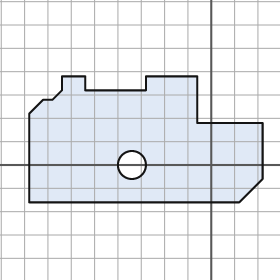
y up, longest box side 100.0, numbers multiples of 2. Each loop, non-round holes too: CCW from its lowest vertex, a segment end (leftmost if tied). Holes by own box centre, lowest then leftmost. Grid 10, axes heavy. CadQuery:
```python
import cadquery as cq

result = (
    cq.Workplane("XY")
    .moveTo(-78.0, -16.0)
    .lineTo(12.0, -16.0)
    .lineTo(22.0, -6.0)
    .lineTo(22.0, 18.0)
    .lineTo(-6.0, 18.0)
    .lineTo(-6.0, 38.0)
    .lineTo(-28.0, 38.0)
    .lineTo(-28.0, 32.0)
    .lineTo(-54.0, 32.0)
    .lineTo(-54.0, 38.0)
    .lineTo(-64.0, 38.0)
    .lineTo(-64.0, 32.0)
    .lineTo(-68.0, 28.0)
    .lineTo(-72.0, 28.0)
    .lineTo(-78.0, 22.0)
    .close()
    .moveTo(-34.0, 0.0)
    .circle(6.0)
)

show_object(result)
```